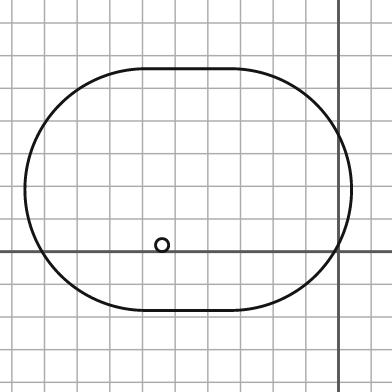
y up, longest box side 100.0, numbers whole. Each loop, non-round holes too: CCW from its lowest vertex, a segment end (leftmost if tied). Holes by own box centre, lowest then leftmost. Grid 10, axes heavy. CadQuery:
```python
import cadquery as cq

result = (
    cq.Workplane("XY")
    .moveTo(-59.0, -18.0)
    .lineTo(-33.0, -18.0)
    .threePointArc((4.0, 19.0), (-33.0, 56.0))
    .lineTo(-59.0, 56.0)
    .threePointArc((-96.0, 19.0), (-59.0, -18.0))
    .close()
    .moveTo(-54.0, 2.0)
    .circle(2.0)
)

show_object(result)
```